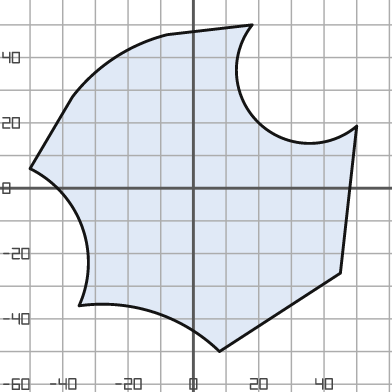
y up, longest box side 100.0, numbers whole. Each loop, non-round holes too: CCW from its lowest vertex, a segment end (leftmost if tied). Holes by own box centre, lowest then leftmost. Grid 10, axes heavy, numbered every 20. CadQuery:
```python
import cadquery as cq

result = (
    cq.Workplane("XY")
    .moveTo(8.0, -50.0)
    .lineTo(45.0, -26.0)
    .lineTo(50.0, 19.0)
    .threePointArc((20.0, 20.0), (18.0, 50.0))
    .lineTo(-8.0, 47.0)
    .threePointArc((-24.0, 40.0), (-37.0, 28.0))
    .lineTo(-50.0, 6.0)
    .threePointArc((-34.0, -12.0), (-35.0, -36.0))
    .threePointArc((-12.0, -38.0), (8.0, -50.0))
    .close()
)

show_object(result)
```